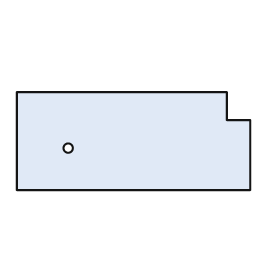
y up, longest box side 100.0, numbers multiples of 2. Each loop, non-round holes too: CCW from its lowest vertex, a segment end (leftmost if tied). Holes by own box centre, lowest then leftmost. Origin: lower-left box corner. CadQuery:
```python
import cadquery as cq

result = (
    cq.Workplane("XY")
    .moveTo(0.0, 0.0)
    .lineTo(100.0, 0.0)
    .lineTo(100.0, 30.0)
    .lineTo(90.0, 30.0)
    .lineTo(90.0, 42.0)
    .lineTo(0.0, 42.0)
    .close()
    .moveTo(22.0, 18.0)
    .circle(2.0)
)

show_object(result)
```